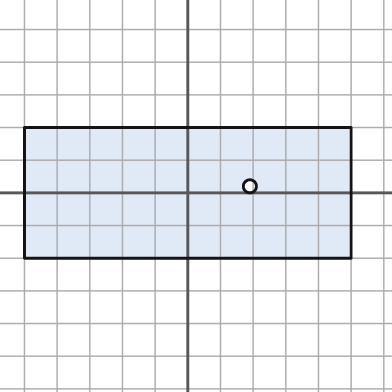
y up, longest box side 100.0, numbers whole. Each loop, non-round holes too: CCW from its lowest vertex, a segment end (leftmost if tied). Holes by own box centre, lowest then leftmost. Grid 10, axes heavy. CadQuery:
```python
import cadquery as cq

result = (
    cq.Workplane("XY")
    .moveTo(-50.0, -20.0)
    .lineTo(50.0, -20.0)
    .lineTo(50.0, 20.0)
    .lineTo(-50.0, 20.0)
    .close()
    .moveTo(19.0, 2.0)
    .circle(2.0)
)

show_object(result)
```